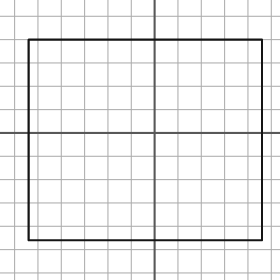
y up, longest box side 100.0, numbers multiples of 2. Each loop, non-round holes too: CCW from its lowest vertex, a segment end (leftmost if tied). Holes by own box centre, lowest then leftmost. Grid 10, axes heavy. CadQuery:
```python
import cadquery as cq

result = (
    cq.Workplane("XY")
    .moveTo(-54.0, -46.0)
    .lineTo(46.0, -46.0)
    .lineTo(46.0, 40.0)
    .lineTo(-54.0, 40.0)
    .close()
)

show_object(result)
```